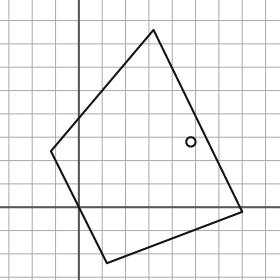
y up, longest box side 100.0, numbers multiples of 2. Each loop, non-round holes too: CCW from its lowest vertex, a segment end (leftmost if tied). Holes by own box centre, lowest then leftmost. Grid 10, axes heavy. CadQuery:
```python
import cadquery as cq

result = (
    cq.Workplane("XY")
    .moveTo(12.0, -24.0)
    .lineTo(70.0, -2.0)
    .lineTo(32.0, 76.0)
    .lineTo(-12.0, 24.0)
    .close()
    .moveTo(48.0, 28.0)
    .circle(2.0)
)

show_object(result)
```